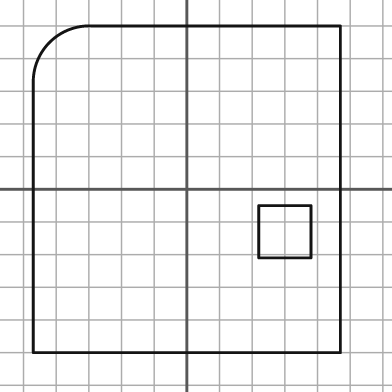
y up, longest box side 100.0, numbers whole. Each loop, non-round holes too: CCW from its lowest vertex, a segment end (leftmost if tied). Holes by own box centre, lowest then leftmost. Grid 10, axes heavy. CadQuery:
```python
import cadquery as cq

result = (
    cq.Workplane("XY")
    .moveTo(-47.0, -50.0)
    .lineTo(47.0, -50.0)
    .lineTo(47.0, 50.0)
    .lineTo(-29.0, 50.0)
    .threePointArc((-42.0, 45.0), (-47.0, 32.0))
    .close()
    .moveTo(22.0, -21.0)
    .lineTo(38.0, -21.0)
    .lineTo(38.0, -5.0)
    .lineTo(22.0, -5.0)
    .close()
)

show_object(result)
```